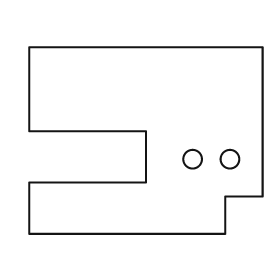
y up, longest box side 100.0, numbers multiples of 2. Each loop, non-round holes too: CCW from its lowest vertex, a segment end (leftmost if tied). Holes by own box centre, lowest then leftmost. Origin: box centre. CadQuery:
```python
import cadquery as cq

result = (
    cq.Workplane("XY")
    .moveTo(-50.0, -40.0)
    .lineTo(34.0, -40.0)
    .lineTo(34.0, -24.0)
    .lineTo(50.0, -24.0)
    .lineTo(50.0, 40.0)
    .lineTo(-50.0, 40.0)
    .lineTo(-50.0, 4.0)
    .lineTo(0.0, 4.0)
    .lineTo(0.0, -18.0)
    .lineTo(-50.0, -18.0)
    .close()
    .moveTo(20.0, -8.0)
    .circle(4.0)
    .moveTo(36.0, -8.0)
    .circle(4.0)
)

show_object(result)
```